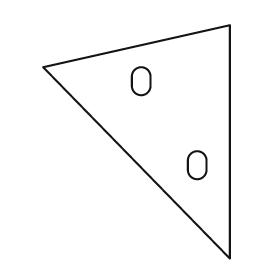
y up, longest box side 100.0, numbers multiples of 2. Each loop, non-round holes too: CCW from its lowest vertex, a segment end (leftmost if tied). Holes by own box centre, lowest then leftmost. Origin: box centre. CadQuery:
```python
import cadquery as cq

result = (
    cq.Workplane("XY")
    .moveTo(40.0, -50.0)
    .lineTo(40.0, 50.0)
    .lineTo(-40.0, 32.0)
    .close()
    .moveTo(22.0, -12.0)
    .threePointArc((26.0, -16.0), (30.0, -12.0))
    .lineTo(30.0, -8.0)
    .threePointArc((26.0, -4.0), (22.0, -8.0))
    .close()
    .moveTo(-2.0, 24.0)
    .threePointArc((2.0, 20.0), (6.0, 24.0))
    .lineTo(6.0, 28.0)
    .threePointArc((2.0, 32.0), (-2.0, 28.0))
    .close()
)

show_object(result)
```